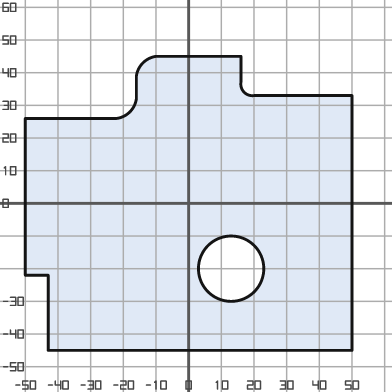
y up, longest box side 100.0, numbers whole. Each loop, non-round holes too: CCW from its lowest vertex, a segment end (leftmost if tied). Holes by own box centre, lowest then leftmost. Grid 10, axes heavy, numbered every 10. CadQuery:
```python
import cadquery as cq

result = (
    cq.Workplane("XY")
    .moveTo(-43.0, -45.0)
    .lineTo(50.0, -45.0)
    .lineTo(50.0, 33.0)
    .lineTo(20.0, 33.0)
    .threePointArc((17.0, 34.0), (16.0, 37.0))
    .lineTo(16.0, 45.0)
    .lineTo(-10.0, 45.0)
    .threePointArc((-14.0, 43.0), (-16.0, 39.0))
    .lineTo(-16.0, 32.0)
    .threePointArc((-18.0, 28.0), (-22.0, 26.0))
    .lineTo(-50.0, 26.0)
    .lineTo(-50.0, -22.0)
    .lineTo(-43.0, -22.0)
    .close()
    .moveTo(13.0, -20.0)
    .circle(10.0)
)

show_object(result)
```